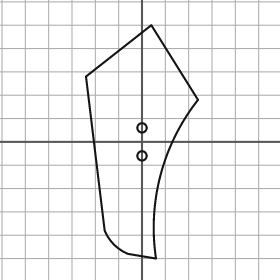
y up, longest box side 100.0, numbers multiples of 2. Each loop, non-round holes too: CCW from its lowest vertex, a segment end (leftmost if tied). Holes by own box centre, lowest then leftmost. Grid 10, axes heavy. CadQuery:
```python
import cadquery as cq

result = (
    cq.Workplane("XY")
    .moveTo(6.0, -50.0)
    .threePointArc((8.0, -14.0), (24.0, 18.0))
    .lineTo(4.0, 50.0)
    .lineTo(-24.0, 28.0)
    .lineTo(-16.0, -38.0)
    .threePointArc((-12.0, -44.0), (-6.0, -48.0))
    .close()
    .moveTo(0.0, -6.0)
    .circle(2.0)
    .moveTo(0.0, 6.0)
    .circle(2.0)
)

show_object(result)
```